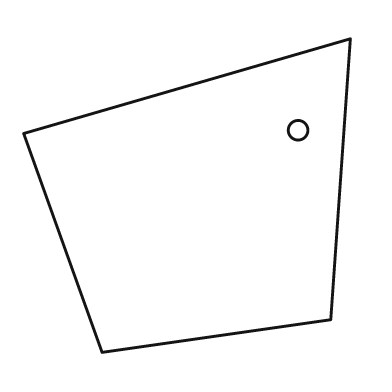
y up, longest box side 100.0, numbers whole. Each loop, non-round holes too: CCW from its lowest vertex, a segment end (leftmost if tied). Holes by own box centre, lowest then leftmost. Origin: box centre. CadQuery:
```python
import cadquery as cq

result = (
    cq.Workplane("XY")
    .moveTo(-26.0, -48.0)
    .lineTo(44.0, -38.0)
    .lineTo(50.0, 48.0)
    .lineTo(-50.0, 19.0)
    .close()
    .moveTo(34.0, 20.0)
    .circle(3.0)
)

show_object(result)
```